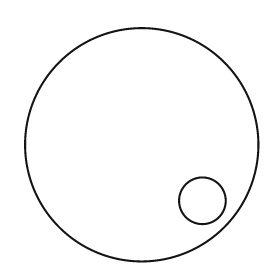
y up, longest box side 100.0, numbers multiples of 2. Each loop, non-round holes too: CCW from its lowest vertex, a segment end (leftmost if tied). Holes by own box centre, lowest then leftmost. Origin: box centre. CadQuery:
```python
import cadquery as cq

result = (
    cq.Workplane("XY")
    .moveTo(0.0, 0.0)
    .circle(50.0)
    .moveTo(26.0, -24.0)
    .circle(10.0)
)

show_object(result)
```